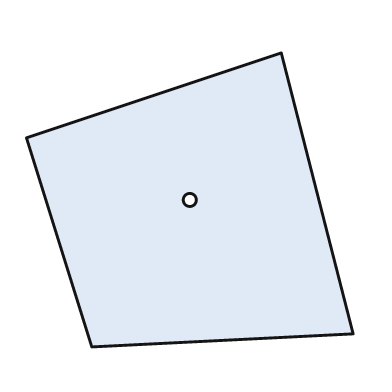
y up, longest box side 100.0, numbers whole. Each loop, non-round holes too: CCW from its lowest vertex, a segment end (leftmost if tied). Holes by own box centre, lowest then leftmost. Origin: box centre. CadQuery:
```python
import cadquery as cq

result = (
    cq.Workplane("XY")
    .moveTo(-30.0, -45.0)
    .lineTo(50.0, -41.0)
    .lineTo(28.0, 45.0)
    .lineTo(-50.0, 19.0)
    .close()
    .moveTo(0.0, 0.0)
    .circle(2.0)
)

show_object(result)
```